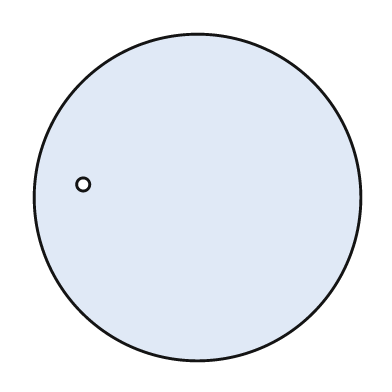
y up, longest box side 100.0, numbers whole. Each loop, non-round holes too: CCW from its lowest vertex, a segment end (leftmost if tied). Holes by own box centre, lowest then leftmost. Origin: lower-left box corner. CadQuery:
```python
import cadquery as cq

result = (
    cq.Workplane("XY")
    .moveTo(50.0, 50.0)
    .circle(50.0)
    .moveTo(15.0, 54.0)
    .circle(2.0)
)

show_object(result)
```